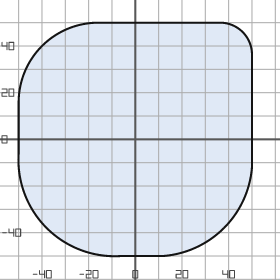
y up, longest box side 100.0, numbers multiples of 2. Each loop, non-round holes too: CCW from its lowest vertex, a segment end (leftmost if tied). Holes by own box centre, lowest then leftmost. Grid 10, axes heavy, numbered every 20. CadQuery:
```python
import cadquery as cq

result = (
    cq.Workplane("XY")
    .moveTo(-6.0, -50.0)
    .lineTo(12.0, -50.0)
    .threePointArc((38.0, -38.0), (50.0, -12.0))
    .lineTo(50.0, 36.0)
    .threePointArc((46.0, 46.0), (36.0, 50.0))
    .lineTo(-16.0, 50.0)
    .threePointArc((-40.0, 40.0), (-50.0, 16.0))
    .lineTo(-50.0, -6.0)
    .threePointArc((-38.0, -38.0), (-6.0, -50.0))
    .close()
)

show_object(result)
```